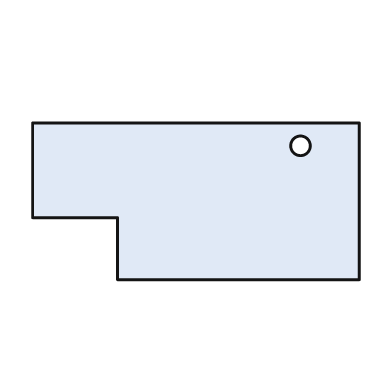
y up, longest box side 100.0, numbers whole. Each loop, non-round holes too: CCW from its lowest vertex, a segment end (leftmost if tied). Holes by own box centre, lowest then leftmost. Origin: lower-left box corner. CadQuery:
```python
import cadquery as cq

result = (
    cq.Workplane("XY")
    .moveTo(26.0, 0.0)
    .lineTo(100.0, 0.0)
    .lineTo(100.0, 48.0)
    .lineTo(0.0, 48.0)
    .lineTo(0.0, 19.0)
    .lineTo(26.0, 19.0)
    .close()
    .moveTo(82.0, 41.0)
    .circle(3.0)
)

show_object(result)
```